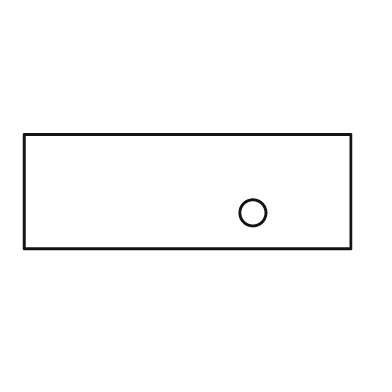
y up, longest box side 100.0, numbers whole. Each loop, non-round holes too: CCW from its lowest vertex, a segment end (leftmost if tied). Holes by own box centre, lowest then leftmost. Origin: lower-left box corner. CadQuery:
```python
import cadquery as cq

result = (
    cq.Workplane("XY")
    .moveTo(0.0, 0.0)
    .lineTo(100.0, 0.0)
    .lineTo(100.0, 35.0)
    .lineTo(0.0, 35.0)
    .close()
    .moveTo(70.0, 11.0)
    .circle(4.0)
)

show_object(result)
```